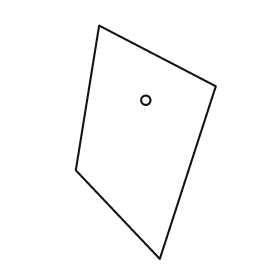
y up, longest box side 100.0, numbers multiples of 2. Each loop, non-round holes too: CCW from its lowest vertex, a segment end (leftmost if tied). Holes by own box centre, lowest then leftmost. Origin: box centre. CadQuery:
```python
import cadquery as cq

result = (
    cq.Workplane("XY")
    .moveTo(6.0, -50.0)
    .lineTo(30.0, 24.0)
    .lineTo(-20.0, 50.0)
    .lineTo(-30.0, -12.0)
    .close()
    .moveTo(0.0, 18.0)
    .circle(2.0)
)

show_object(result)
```